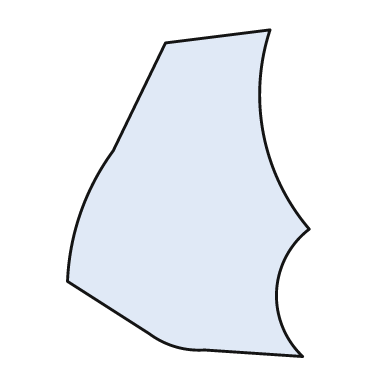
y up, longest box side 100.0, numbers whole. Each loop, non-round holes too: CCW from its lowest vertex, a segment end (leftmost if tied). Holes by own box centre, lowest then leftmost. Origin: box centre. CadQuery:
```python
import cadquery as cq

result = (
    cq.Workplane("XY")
    .moveTo(35.0, -50.0)
    .threePointArc((27.0, -30.0), (37.0, -11.0))
    .threePointArc((23.0, 18.0), (25.0, 50.0))
    .lineTo(-7.0, 46.0)
    .lineTo(-23.0, 13.0)
    .threePointArc((-33.0, -6.0), (-37.0, -27.0))
    .lineTo(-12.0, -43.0)
    .threePointArc((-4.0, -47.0), (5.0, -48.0))
    .close()
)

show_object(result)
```